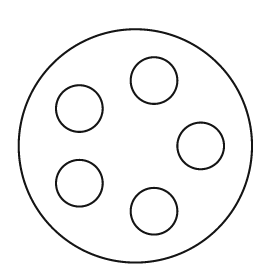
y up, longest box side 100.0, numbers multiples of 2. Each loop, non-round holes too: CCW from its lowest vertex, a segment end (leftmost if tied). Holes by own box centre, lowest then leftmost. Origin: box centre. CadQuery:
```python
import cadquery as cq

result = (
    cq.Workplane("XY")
    .moveTo(0.0, 0.0)
    .circle(50.0)
    .moveTo(8.0, -28.0)
    .circle(10.0)
    .moveTo(-24.0, -16.0)
    .circle(10.0)
    .moveTo(28.0, 0.0)
    .circle(10.0)
    .moveTo(-24.0, 16.0)
    .circle(10.0)
    .moveTo(8.0, 28.0)
    .circle(10.0)
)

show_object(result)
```